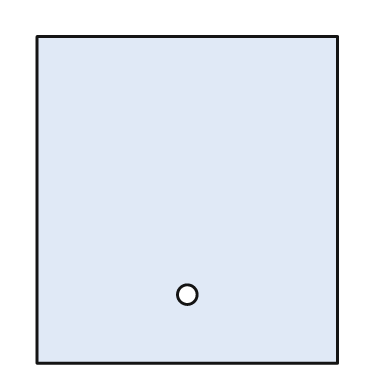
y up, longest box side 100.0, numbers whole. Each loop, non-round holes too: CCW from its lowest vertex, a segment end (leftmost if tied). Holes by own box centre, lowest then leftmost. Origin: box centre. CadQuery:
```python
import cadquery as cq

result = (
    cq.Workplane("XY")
    .moveTo(-46.0, -50.0)
    .lineTo(46.0, -50.0)
    .lineTo(46.0, 50.0)
    .lineTo(-46.0, 50.0)
    .close()
    .moveTo(0.0, -29.0)
    .circle(3.0)
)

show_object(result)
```